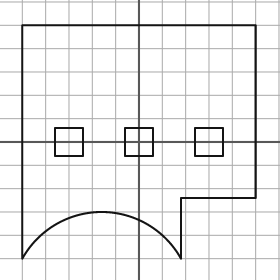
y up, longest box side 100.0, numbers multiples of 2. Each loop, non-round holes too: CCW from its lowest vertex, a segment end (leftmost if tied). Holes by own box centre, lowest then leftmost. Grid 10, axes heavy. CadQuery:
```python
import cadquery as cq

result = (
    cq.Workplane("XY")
    .moveTo(-50.0, -50.0)
    .threePointArc((-16.0, -30.0), (18.0, -50.0))
    .lineTo(18.0, -24.0)
    .lineTo(50.0, -24.0)
    .lineTo(50.0, 50.0)
    .lineTo(-50.0, 50.0)
    .close()
    .moveTo(-36.0, -6.0)
    .lineTo(-24.0, -6.0)
    .lineTo(-24.0, 6.0)
    .lineTo(-36.0, 6.0)
    .close()
    .moveTo(-6.0, -6.0)
    .lineTo(6.0, -6.0)
    .lineTo(6.0, 6.0)
    .lineTo(-6.0, 6.0)
    .close()
    .moveTo(24.0, -6.0)
    .lineTo(36.0, -6.0)
    .lineTo(36.0, 6.0)
    .lineTo(24.0, 6.0)
    .close()
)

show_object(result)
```